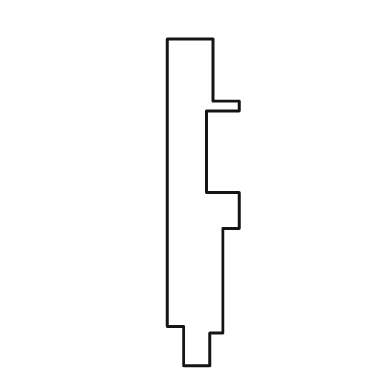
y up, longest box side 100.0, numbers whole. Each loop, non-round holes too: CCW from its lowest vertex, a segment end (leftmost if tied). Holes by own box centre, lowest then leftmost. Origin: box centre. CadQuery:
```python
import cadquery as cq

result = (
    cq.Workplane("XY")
    .moveTo(-6.0, -50.0)
    .lineTo(2.0, -50.0)
    .lineTo(2.0, -40.0)
    .lineTo(6.0, -40.0)
    .lineTo(6.0, -8.0)
    .lineTo(11.0, -8.0)
    .lineTo(11.0, 3.0)
    .lineTo(1.0, 3.0)
    .lineTo(1.0, 28.0)
    .lineTo(11.0, 28.0)
    .lineTo(11.0, 31.0)
    .lineTo(3.0, 31.0)
    .lineTo(3.0, 50.0)
    .lineTo(-11.0, 50.0)
    .lineTo(-11.0, -38.0)
    .lineTo(-6.0, -38.0)
    .close()
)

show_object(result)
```